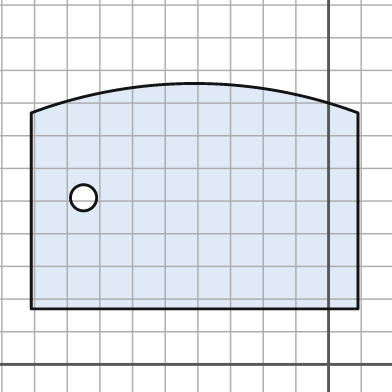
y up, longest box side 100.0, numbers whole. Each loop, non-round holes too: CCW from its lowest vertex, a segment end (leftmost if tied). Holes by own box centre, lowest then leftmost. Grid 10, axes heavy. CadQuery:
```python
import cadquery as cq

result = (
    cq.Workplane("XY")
    .moveTo(-91.0, 17.0)
    .lineTo(9.0, 17.0)
    .lineTo(9.0, 77.0)
    .threePointArc((-41.0, 86.0), (-91.0, 77.0))
    .close()
    .moveTo(-75.0, 51.0)
    .circle(4.0)
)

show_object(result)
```